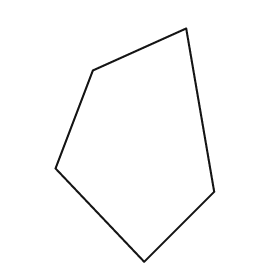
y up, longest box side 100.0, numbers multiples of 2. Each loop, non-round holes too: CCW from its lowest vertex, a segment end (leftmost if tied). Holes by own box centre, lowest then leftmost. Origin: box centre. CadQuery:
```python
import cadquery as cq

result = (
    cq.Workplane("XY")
    .moveTo(4.0, -50.0)
    .lineTo(34.0, -20.0)
    .lineTo(22.0, 50.0)
    .lineTo(-18.0, 32.0)
    .lineTo(-34.0, -10.0)
    .close()
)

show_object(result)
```